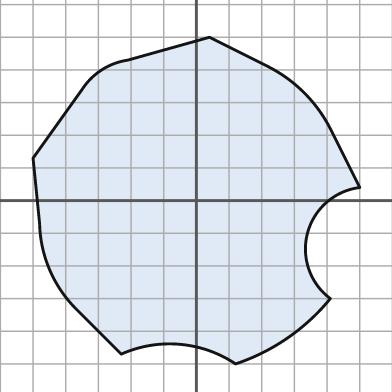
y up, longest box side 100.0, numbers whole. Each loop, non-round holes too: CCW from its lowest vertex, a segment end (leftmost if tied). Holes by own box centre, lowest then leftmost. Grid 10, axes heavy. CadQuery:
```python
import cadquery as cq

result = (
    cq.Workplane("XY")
    .moveTo(12.0, -50.0)
    .threePointArc((28.0, -42.0), (41.0, -30.0))
    .threePointArc((34.0, -10.0), (50.0, 4.0))
    .lineTo(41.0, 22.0)
    .threePointArc((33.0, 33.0), (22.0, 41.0))
    .lineTo(4.0, 50.0)
    .lineTo(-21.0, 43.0)
    .threePointArc((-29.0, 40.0), (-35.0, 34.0))
    .lineTo(-50.0, 13.0)
    .lineTo(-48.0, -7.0)
    .threePointArc((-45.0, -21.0), (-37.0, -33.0))
    .lineTo(-23.0, -47.0)
    .threePointArc((-5.0, -44.0), (12.0, -50.0))
    .close()
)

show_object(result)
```